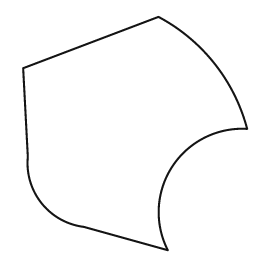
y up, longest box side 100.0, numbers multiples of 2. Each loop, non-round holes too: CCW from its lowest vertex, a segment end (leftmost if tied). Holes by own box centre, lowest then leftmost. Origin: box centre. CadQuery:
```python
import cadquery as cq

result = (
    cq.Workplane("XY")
    .moveTo(14.0, -50.0)
    .threePointArc((16.0, -14.0), (48.0, 2.0))
    .threePointArc((34.0, 30.0), (10.0, 50.0))
    .lineTo(-48.0, 28.0)
    .lineTo(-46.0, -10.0)
    .threePointArc((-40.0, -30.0), (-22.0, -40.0))
    .close()
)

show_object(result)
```